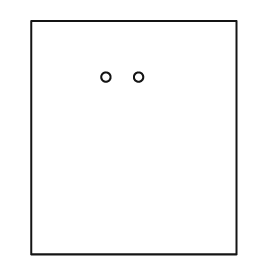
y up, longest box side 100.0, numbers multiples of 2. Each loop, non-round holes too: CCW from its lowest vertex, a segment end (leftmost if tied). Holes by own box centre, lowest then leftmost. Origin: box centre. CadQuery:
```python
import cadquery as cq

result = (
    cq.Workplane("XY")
    .moveTo(-44.0, -50.0)
    .lineTo(44.0, -50.0)
    .lineTo(44.0, 50.0)
    .lineTo(-44.0, 50.0)
    .close()
    .moveTo(-12.0, 26.0)
    .circle(2.0)
    .moveTo(2.0, 26.0)
    .circle(2.0)
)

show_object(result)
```